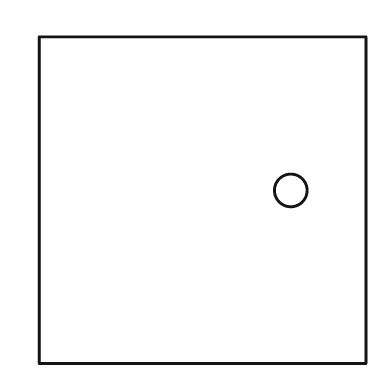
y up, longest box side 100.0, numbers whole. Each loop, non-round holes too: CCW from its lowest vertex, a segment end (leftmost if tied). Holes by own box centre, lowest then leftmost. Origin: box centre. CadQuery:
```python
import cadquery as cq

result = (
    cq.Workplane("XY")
    .moveTo(-50.0, -50.0)
    .lineTo(50.0, -50.0)
    .lineTo(50.0, 50.0)
    .lineTo(-50.0, 50.0)
    .close()
    .moveTo(27.0, 3.0)
    .circle(5.0)
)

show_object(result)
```